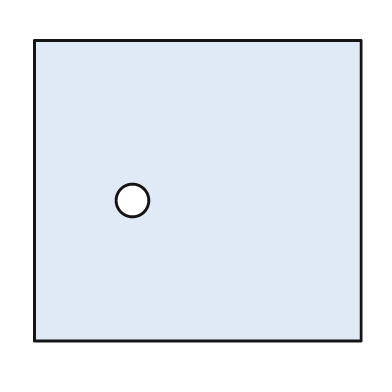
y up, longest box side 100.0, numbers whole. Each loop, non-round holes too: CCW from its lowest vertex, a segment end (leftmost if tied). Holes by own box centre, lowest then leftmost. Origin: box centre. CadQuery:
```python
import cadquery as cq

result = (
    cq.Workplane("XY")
    .moveTo(-50.0, -46.0)
    .lineTo(50.0, -46.0)
    .lineTo(50.0, 46.0)
    .lineTo(-50.0, 46.0)
    .close()
    .moveTo(-20.0, -3.0)
    .circle(5.0)
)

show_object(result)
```